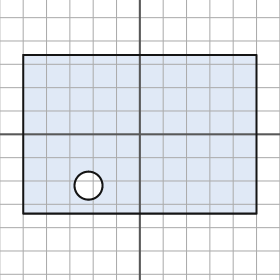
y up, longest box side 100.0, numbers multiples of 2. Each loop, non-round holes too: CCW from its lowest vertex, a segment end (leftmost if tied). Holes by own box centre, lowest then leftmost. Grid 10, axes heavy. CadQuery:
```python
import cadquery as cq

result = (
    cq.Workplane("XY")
    .moveTo(-50.0, -34.0)
    .lineTo(50.0, -34.0)
    .lineTo(50.0, 34.0)
    .lineTo(-50.0, 34.0)
    .close()
    .moveTo(-22.0, -22.0)
    .circle(6.0)
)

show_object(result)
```